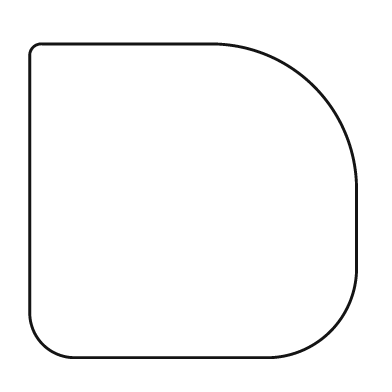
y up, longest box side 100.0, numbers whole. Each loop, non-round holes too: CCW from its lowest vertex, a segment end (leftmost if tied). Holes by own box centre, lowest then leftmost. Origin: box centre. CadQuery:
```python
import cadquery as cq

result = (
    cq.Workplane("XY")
    .moveTo(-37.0, -48.0)
    .lineTo(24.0, -48.0)
    .threePointArc((42.0, -40.0), (50.0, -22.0))
    .lineTo(50.0, 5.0)
    .threePointArc((37.0, 35.0), (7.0, 48.0))
    .lineTo(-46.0, 48.0)
    .threePointArc((-49.0, 47.0), (-50.0, 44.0))
    .lineTo(-50.0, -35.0)
    .threePointArc((-46.0, -44.0), (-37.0, -48.0))
    .close()
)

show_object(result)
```